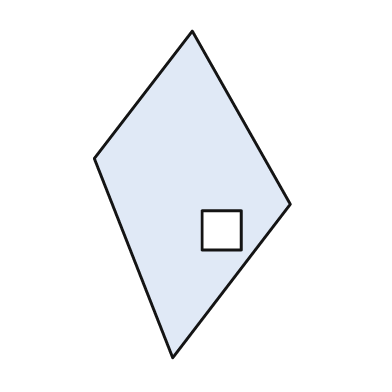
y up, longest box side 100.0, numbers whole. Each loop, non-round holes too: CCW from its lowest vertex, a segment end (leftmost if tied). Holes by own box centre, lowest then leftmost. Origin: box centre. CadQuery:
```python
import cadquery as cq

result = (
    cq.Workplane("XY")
    .moveTo(-6.0, -50.0)
    .lineTo(30.0, -3.0)
    .lineTo(0.0, 50.0)
    .lineTo(-30.0, 11.0)
    .close()
    .moveTo(3.0, -17.0)
    .lineTo(15.0, -17.0)
    .lineTo(15.0, -5.0)
    .lineTo(3.0, -5.0)
    .close()
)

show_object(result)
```